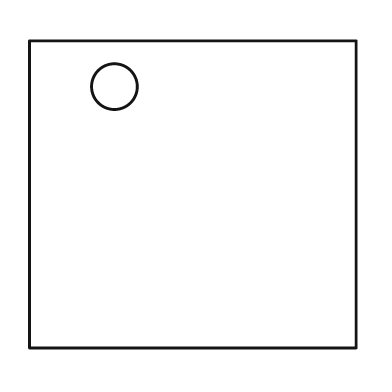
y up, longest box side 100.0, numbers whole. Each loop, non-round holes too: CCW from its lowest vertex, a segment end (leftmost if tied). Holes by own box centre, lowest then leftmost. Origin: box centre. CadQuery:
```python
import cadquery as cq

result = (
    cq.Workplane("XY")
    .moveTo(-50.0, -47.0)
    .lineTo(50.0, -47.0)
    .lineTo(50.0, 47.0)
    .lineTo(-50.0, 47.0)
    .close()
    .moveTo(-24.0, 33.0)
    .circle(7.0)
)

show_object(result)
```